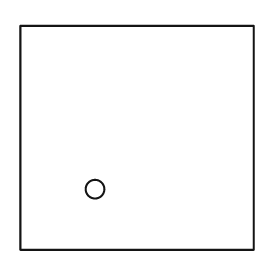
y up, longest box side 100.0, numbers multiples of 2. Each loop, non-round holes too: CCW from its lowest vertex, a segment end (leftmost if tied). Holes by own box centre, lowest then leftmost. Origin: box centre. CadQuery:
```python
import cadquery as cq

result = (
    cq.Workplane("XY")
    .moveTo(-50.0, -48.0)
    .lineTo(50.0, -48.0)
    .lineTo(50.0, 48.0)
    .lineTo(-50.0, 48.0)
    .close()
    .moveTo(-18.0, -22.0)
    .circle(4.0)
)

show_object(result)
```